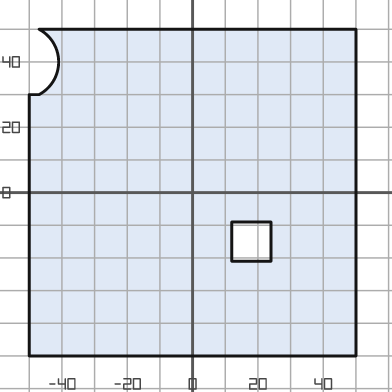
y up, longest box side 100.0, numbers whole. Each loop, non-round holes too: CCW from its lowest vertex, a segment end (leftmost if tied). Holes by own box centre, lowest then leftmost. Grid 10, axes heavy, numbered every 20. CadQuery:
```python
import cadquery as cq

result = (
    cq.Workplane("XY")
    .moveTo(-50.0, -50.0)
    .lineTo(50.0, -50.0)
    .lineTo(50.0, 50.0)
    .lineTo(-47.0, 50.0)
    .threePointArc((-41.0, 40.0), (-47.0, 30.0))
    .lineTo(-50.0, 30.0)
    .close()
    .moveTo(12.0, -21.0)
    .lineTo(24.0, -21.0)
    .lineTo(24.0, -9.0)
    .lineTo(12.0, -9.0)
    .close()
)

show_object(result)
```